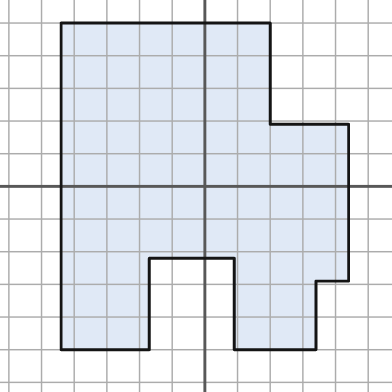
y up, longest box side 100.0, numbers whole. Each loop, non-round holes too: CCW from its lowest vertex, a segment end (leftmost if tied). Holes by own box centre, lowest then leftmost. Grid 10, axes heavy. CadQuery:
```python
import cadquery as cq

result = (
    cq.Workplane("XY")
    .moveTo(-44.0, -50.0)
    .lineTo(-17.0, -50.0)
    .lineTo(-17.0, -22.0)
    .lineTo(9.0, -22.0)
    .lineTo(9.0, -50.0)
    .lineTo(34.0, -50.0)
    .lineTo(34.0, -29.0)
    .lineTo(44.0, -29.0)
    .lineTo(44.0, 19.0)
    .lineTo(20.0, 19.0)
    .lineTo(20.0, 50.0)
    .lineTo(-44.0, 50.0)
    .close()
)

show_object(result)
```